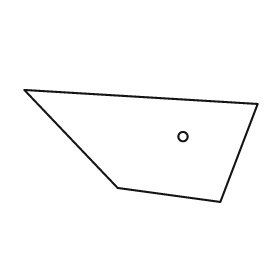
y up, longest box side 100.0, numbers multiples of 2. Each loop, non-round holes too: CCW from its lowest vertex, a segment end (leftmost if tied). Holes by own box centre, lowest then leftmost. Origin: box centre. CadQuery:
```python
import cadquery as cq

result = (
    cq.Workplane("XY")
    .moveTo(34.0, -24.0)
    .lineTo(50.0, 18.0)
    .lineTo(-50.0, 24.0)
    .lineTo(-10.0, -18.0)
    .close()
    .moveTo(18.0, 4.0)
    .circle(2.0)
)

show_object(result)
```